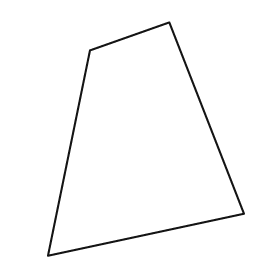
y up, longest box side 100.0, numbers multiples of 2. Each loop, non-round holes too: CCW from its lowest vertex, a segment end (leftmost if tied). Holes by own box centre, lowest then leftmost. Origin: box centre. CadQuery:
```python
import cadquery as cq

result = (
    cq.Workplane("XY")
    .moveTo(-42.0, -50.0)
    .lineTo(42.0, -32.0)
    .lineTo(10.0, 50.0)
    .lineTo(-24.0, 38.0)
    .close()
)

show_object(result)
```